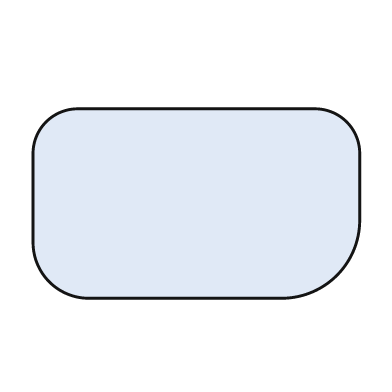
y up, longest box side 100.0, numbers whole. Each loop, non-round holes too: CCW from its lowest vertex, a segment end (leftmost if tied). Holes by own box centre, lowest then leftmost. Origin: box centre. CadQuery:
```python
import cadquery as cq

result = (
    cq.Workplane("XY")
    .moveTo(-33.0, -29.0)
    .lineTo(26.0, -29.0)
    .threePointArc((43.0, -22.0), (50.0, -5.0))
    .lineTo(50.0, 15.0)
    .threePointArc((46.0, 25.0), (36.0, 29.0))
    .lineTo(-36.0, 29.0)
    .threePointArc((-46.0, 25.0), (-50.0, 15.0))
    .lineTo(-50.0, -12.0)
    .threePointArc((-45.0, -24.0), (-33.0, -29.0))
    .close()
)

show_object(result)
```